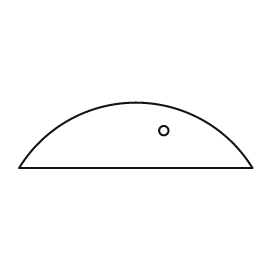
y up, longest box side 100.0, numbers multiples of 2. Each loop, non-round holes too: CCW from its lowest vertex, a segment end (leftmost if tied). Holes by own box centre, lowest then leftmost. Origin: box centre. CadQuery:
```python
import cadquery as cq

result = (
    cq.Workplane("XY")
    .moveTo(-50.0, -14.0)
    .lineTo(50.0, -14.0)
    .threePointArc((0.0, 14.0), (-50.0, -14.0))
    .close()
    .moveTo(12.0, 2.0)
    .circle(2.0)
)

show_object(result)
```